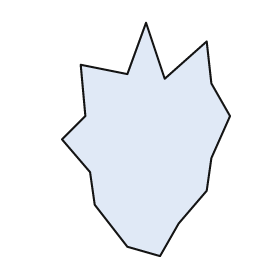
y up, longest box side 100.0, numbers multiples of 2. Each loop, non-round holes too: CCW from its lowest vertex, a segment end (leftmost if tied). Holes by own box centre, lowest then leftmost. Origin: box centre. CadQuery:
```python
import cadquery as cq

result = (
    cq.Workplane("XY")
    .moveTo(6.0, -50.0)
    .lineTo(14.0, -36.0)
    .lineTo(26.0, -22.0)
    .lineTo(28.0, -8.0)
    .lineTo(36.0, 10.0)
    .lineTo(28.0, 24.0)
    .lineTo(26.0, 42.0)
    .lineTo(8.0, 26.0)
    .lineTo(0.0, 50.0)
    .lineTo(-8.0, 28.0)
    .lineTo(-28.0, 32.0)
    .lineTo(-26.0, 10.0)
    .lineTo(-36.0, 0.0)
    .lineTo(-24.0, -14.0)
    .lineTo(-22.0, -28.0)
    .lineTo(-8.0, -46.0)
    .close()
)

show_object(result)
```